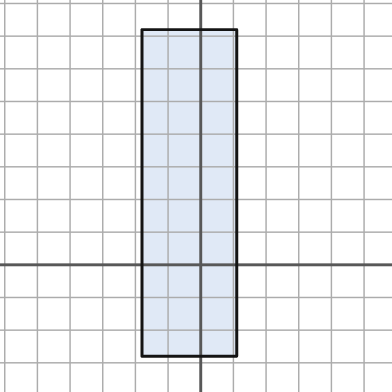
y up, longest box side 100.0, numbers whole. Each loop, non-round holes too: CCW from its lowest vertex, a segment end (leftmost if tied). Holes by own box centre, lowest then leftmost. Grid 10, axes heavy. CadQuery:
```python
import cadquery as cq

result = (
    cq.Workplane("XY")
    .moveTo(-18.0, -28.0)
    .lineTo(11.0, -28.0)
    .lineTo(11.0, 72.0)
    .lineTo(-18.0, 72.0)
    .close()
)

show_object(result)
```